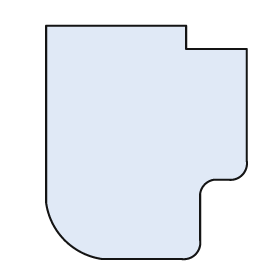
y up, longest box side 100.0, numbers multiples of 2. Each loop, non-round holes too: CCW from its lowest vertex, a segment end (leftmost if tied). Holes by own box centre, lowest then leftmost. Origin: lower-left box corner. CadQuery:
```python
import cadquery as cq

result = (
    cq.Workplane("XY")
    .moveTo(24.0, 0.0)
    .lineTo(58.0, 0.0)
    .threePointArc((64.0, 2.0), (66.0, 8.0))
    .lineTo(66.0, 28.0)
    .threePointArc((68.0, 32.0), (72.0, 34.0))
    .lineTo(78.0, 34.0)
    .threePointArc((84.0, 36.0), (86.0, 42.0))
    .lineTo(86.0, 90.0)
    .lineTo(60.0, 90.0)
    .lineTo(60.0, 100.0)
    .lineTo(0.0, 100.0)
    .lineTo(0.0, 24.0)
    .threePointArc((8.0, 8.0), (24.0, 0.0))
    .close()
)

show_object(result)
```